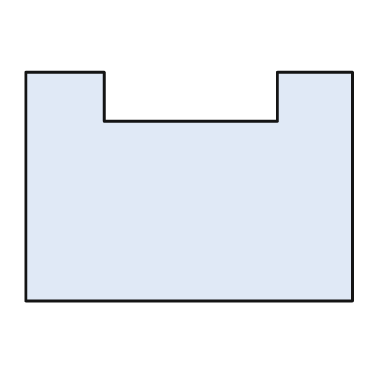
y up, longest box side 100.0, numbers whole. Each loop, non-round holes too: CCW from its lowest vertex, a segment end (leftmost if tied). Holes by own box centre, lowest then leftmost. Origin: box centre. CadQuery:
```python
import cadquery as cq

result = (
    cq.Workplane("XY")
    .moveTo(-50.0, -35.0)
    .lineTo(50.0, -35.0)
    .lineTo(50.0, 35.0)
    .lineTo(27.0, 35.0)
    .lineTo(27.0, 20.0)
    .lineTo(-26.0, 20.0)
    .lineTo(-26.0, 35.0)
    .lineTo(-50.0, 35.0)
    .close()
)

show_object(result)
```